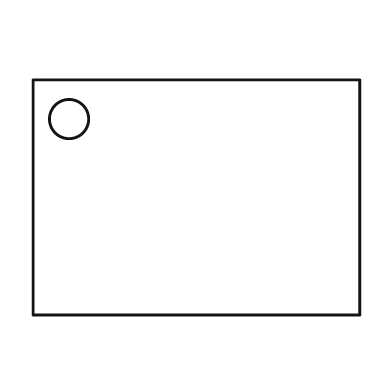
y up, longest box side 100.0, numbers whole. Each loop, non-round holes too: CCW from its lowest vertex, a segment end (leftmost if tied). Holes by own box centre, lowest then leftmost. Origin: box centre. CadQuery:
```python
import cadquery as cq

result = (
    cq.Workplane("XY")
    .moveTo(-50.0, -36.0)
    .lineTo(50.0, -36.0)
    .lineTo(50.0, 36.0)
    .lineTo(-50.0, 36.0)
    .close()
    .moveTo(-39.0, 24.0)
    .circle(6.0)
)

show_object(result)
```